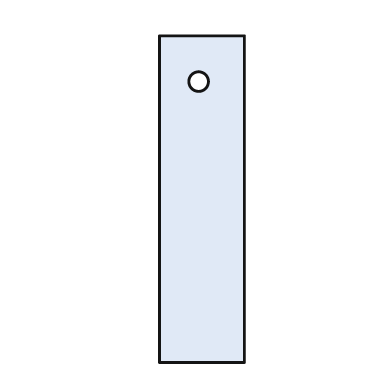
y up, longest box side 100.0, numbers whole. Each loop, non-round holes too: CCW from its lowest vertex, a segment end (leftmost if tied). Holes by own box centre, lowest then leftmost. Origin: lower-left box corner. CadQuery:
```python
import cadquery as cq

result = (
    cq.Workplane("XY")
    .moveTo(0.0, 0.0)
    .lineTo(26.0, 0.0)
    .lineTo(26.0, 100.0)
    .lineTo(0.0, 100.0)
    .close()
    .moveTo(12.0, 86.0)
    .circle(3.0)
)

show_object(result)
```